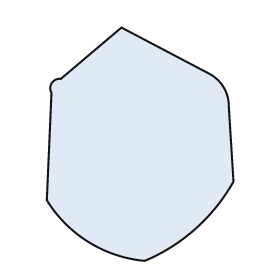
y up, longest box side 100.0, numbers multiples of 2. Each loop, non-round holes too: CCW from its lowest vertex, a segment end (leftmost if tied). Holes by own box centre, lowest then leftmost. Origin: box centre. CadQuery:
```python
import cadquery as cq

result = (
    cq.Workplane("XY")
    .moveTo(2.0, -50.0)
    .threePointArc((24.0, -36.0), (40.0, -16.0))
    .lineTo(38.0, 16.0)
    .threePointArc((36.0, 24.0), (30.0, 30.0))
    .lineTo(-8.0, 50.0)
    .lineTo(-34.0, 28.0)
    .threePointArc((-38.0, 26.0), (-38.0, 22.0))
    .lineTo(-40.0, -24.0)
    .threePointArc((-22.0, -42.0), (2.0, -50.0))
    .close()
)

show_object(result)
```